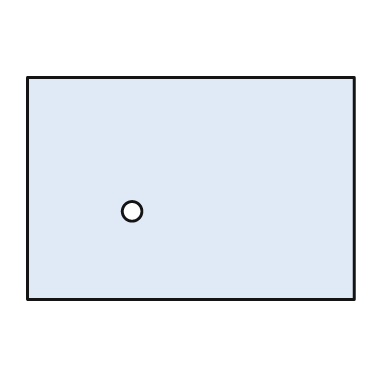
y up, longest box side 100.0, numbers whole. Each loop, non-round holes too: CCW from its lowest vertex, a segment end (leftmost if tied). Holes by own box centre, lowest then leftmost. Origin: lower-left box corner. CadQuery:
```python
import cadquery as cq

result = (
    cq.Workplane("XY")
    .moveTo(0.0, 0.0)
    .lineTo(100.0, 0.0)
    .lineTo(100.0, 68.0)
    .lineTo(0.0, 68.0)
    .close()
    .moveTo(32.0, 27.0)
    .circle(3.0)
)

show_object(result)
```